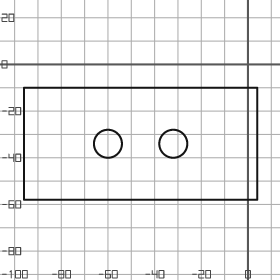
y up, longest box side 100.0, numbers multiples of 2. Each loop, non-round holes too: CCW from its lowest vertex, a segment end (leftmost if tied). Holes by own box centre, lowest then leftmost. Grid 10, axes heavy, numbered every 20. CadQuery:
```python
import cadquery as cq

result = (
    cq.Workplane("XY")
    .moveTo(-96.0, -58.0)
    .lineTo(4.0, -58.0)
    .lineTo(4.0, -10.0)
    .lineTo(-96.0, -10.0)
    .close()
    .moveTo(-60.0, -34.0)
    .circle(6.0)
    .moveTo(-32.0, -34.0)
    .circle(6.0)
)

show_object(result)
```